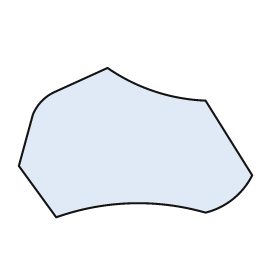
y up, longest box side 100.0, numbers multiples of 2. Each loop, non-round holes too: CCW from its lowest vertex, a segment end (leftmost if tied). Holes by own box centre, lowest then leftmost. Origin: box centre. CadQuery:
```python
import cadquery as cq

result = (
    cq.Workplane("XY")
    .moveTo(-34.0, -32.0)
    .threePointArc((-2.0, -26.0), (30.0, -30.0))
    .threePointArc((42.0, -24.0), (50.0, -14.0))
    .lineTo(30.0, 18.0)
    .threePointArc((8.0, 22.0), (-12.0, 32.0))
    .lineTo(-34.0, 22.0)
    .threePointArc((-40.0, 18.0), (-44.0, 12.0))
    .lineTo(-50.0, -10.0)
    .close()
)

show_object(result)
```